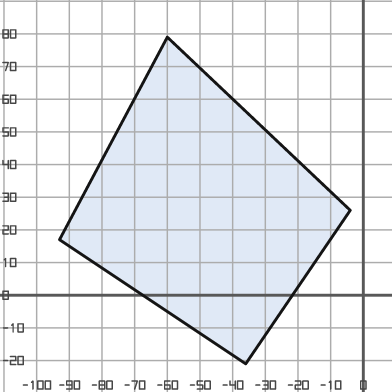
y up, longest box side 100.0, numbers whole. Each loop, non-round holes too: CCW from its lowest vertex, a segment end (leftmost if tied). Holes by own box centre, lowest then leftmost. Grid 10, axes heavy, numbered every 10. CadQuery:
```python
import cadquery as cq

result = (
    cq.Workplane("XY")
    .moveTo(-36.0, -21.0)
    .lineTo(-4.0, 26.0)
    .lineTo(-60.0, 79.0)
    .lineTo(-93.0, 17.0)
    .close()
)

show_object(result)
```